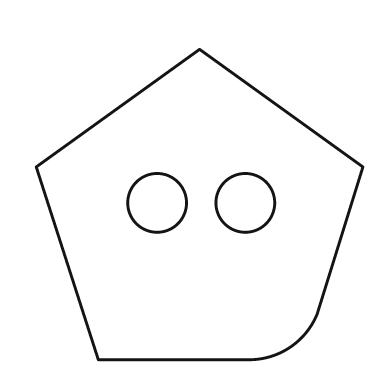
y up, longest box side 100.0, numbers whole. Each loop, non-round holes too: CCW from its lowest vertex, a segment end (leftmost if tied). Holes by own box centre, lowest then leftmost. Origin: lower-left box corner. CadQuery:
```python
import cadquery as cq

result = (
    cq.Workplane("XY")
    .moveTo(19.0, 0.0)
    .lineTo(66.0, 0.0)
    .threePointArc((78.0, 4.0), (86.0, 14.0))
    .lineTo(100.0, 59.0)
    .lineTo(50.0, 95.0)
    .lineTo(0.0, 59.0)
    .close()
    .moveTo(37.0, 48.0)
    .circle(9.0)
    .moveTo(64.0, 48.0)
    .circle(9.0)
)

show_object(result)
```